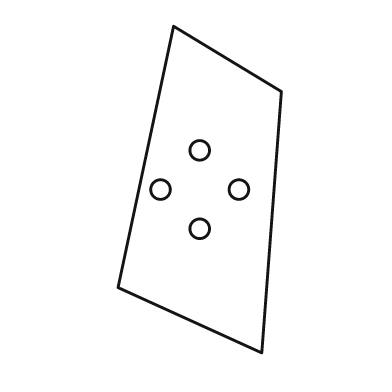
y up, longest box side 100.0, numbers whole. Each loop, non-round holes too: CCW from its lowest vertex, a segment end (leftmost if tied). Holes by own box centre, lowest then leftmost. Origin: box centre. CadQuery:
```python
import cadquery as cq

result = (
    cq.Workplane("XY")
    .moveTo(19.0, -50.0)
    .lineTo(25.0, 30.0)
    .lineTo(-8.0, 50.0)
    .lineTo(-25.0, -30.0)
    .close()
    .moveTo(0.0, -12.0)
    .circle(3.0)
    .moveTo(-12.0, 0.0)
    .circle(3.0)
    .moveTo(12.0, 0.0)
    .circle(3.0)
    .moveTo(0.0, 12.0)
    .circle(3.0)
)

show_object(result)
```